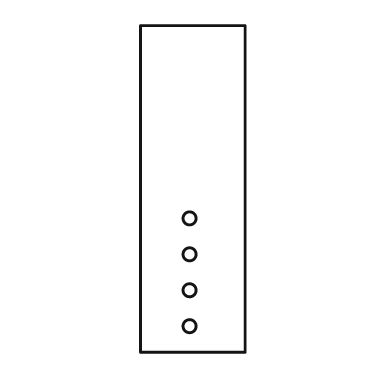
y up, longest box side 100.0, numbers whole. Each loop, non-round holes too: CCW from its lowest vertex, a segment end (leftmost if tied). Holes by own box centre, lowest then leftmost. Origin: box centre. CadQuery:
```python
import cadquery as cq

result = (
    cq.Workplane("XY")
    .moveTo(-16.0, -50.0)
    .lineTo(16.0, -50.0)
    .lineTo(16.0, 50.0)
    .lineTo(-16.0, 50.0)
    .close()
    .moveTo(-1.0, -42.0)
    .circle(2.0)
    .moveTo(-1.0, -31.0)
    .circle(2.0)
    .moveTo(-1.0, -20.0)
    .circle(2.0)
    .moveTo(-1.0, -9.0)
    .circle(2.0)
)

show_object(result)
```